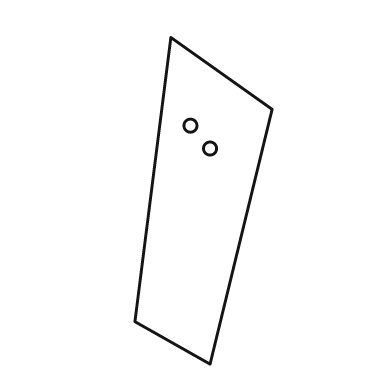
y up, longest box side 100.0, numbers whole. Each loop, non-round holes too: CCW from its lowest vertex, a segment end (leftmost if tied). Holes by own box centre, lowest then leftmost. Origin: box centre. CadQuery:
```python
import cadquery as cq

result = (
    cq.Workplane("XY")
    .moveTo(2.0, -50.0)
    .lineTo(21.0, 28.0)
    .lineTo(-10.0, 50.0)
    .lineTo(-21.0, -37.0)
    .close()
    .moveTo(2.0, 16.0)
    .circle(2.0)
    .moveTo(-4.0, 23.0)
    .circle(2.0)
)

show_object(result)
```